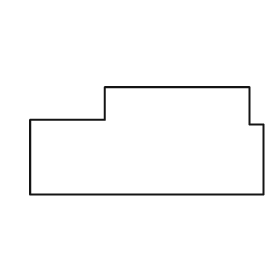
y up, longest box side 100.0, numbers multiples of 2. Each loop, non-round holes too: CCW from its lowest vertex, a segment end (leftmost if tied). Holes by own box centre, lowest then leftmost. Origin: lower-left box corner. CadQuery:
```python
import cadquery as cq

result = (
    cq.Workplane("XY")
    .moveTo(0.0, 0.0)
    .lineTo(100.0, 0.0)
    .lineTo(100.0, 30.0)
    .lineTo(94.0, 30.0)
    .lineTo(94.0, 46.0)
    .lineTo(32.0, 46.0)
    .lineTo(32.0, 32.0)
    .lineTo(0.0, 32.0)
    .close()
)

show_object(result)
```